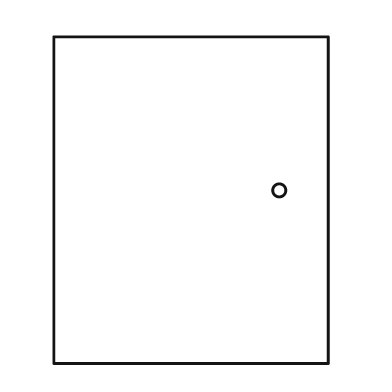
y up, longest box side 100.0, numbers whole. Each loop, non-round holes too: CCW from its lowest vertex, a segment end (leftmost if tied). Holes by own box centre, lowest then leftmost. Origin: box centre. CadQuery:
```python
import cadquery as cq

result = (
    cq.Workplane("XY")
    .moveTo(-42.0, -50.0)
    .lineTo(42.0, -50.0)
    .lineTo(42.0, 50.0)
    .lineTo(-42.0, 50.0)
    .close()
    .moveTo(27.0, 3.0)
    .circle(2.0)
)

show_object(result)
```